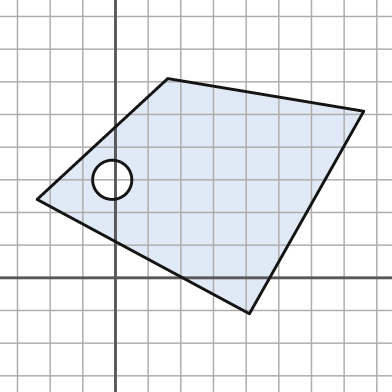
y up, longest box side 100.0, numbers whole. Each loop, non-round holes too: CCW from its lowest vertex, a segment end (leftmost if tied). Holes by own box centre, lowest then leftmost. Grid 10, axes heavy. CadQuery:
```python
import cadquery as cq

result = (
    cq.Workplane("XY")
    .moveTo(41.0, -11.0)
    .lineTo(76.0, 51.0)
    .lineTo(16.0, 61.0)
    .lineTo(-24.0, 24.0)
    .close()
    .moveTo(-1.0, 30.0)
    .circle(6.0)
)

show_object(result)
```